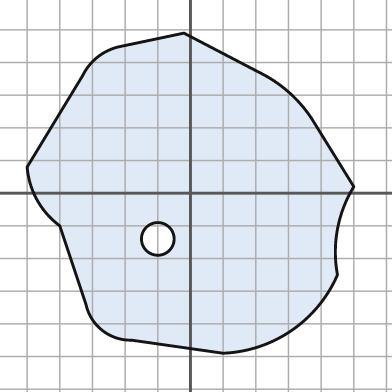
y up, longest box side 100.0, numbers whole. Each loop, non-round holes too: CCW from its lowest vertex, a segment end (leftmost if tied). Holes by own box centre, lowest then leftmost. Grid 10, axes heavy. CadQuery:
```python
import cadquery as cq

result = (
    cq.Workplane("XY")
    .moveTo(10.0, -49.0)
    .threePointArc((31.0, -42.0), (45.0, -25.0))
    .threePointArc((45.0, -11.0), (50.0, 2.0))
    .lineTo(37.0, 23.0)
    .threePointArc((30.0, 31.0), (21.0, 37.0))
    .lineTo(-2.0, 49.0)
    .lineTo(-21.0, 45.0)
    .threePointArc((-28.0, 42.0), (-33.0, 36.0))
    .lineTo(-50.0, 8.0)
    .threePointArc((-47.0, -2.0), (-40.0, -10.0))
    .lineTo(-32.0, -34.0)
    .threePointArc((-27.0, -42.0), (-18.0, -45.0))
    .close()
    .moveTo(-10.0, -14.0)
    .circle(5.0)
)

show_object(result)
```